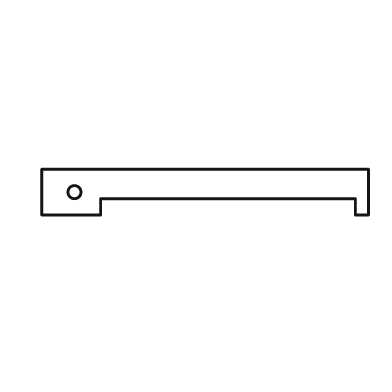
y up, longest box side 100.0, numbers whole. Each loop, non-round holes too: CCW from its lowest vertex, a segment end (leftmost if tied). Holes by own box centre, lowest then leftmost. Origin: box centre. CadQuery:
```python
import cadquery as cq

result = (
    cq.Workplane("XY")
    .moveTo(-50.0, -7.0)
    .lineTo(-32.0, -7.0)
    .lineTo(-32.0, -2.0)
    .lineTo(46.0, -2.0)
    .lineTo(46.0, -7.0)
    .lineTo(50.0, -7.0)
    .lineTo(50.0, 7.0)
    .lineTo(-50.0, 7.0)
    .close()
    .moveTo(-40.0, 0.0)
    .circle(2.0)
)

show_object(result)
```